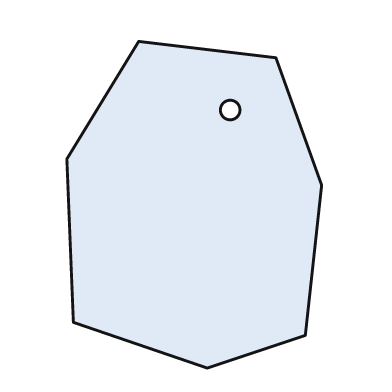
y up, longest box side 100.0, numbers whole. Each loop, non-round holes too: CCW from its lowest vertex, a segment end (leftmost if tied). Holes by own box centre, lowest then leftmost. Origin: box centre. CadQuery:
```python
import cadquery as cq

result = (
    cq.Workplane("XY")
    .moveTo(4.0, -50.0)
    .lineTo(34.0, -40.0)
    .lineTo(39.0, 6.0)
    .lineTo(25.0, 45.0)
    .lineTo(-17.0, 50.0)
    .lineTo(-39.0, 14.0)
    .lineTo(-37.0, -36.0)
    .close()
    .moveTo(11.0, 29.0)
    .circle(3.0)
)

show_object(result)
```